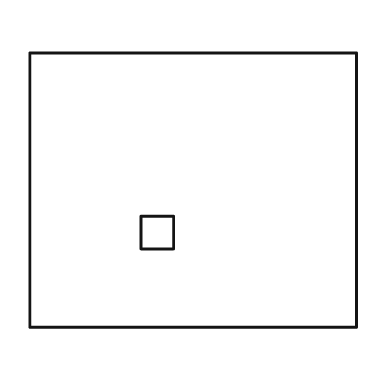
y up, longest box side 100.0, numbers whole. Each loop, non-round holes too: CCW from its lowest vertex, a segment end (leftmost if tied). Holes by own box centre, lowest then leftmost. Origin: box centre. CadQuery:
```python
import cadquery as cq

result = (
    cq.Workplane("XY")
    .moveTo(-50.0, -42.0)
    .lineTo(50.0, -42.0)
    .lineTo(50.0, 42.0)
    .lineTo(-50.0, 42.0)
    .close()
    .moveTo(-16.0, -18.0)
    .lineTo(-6.0, -18.0)
    .lineTo(-6.0, -8.0)
    .lineTo(-16.0, -8.0)
    .close()
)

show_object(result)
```